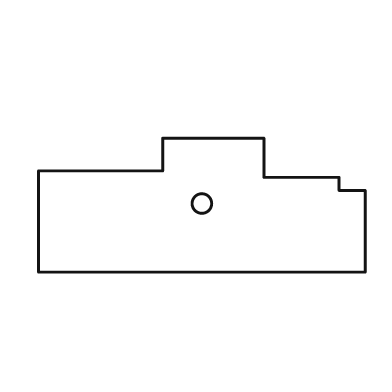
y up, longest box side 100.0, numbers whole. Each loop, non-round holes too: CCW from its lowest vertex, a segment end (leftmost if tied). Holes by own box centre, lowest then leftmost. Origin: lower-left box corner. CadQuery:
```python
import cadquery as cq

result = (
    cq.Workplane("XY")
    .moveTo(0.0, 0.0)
    .lineTo(100.0, 0.0)
    .lineTo(100.0, 25.0)
    .lineTo(92.0, 25.0)
    .lineTo(92.0, 29.0)
    .lineTo(69.0, 29.0)
    .lineTo(69.0, 41.0)
    .lineTo(38.0, 41.0)
    .lineTo(38.0, 31.0)
    .lineTo(0.0, 31.0)
    .close()
    .moveTo(50.0, 21.0)
    .circle(3.0)
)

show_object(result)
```